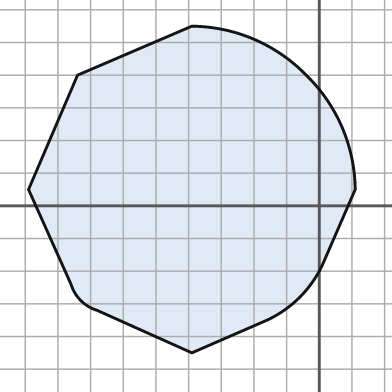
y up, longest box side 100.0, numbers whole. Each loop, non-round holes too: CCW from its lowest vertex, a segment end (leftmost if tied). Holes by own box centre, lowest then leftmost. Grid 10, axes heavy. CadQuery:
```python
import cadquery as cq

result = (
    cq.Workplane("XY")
    .moveTo(-39.0, -45.0)
    .lineTo(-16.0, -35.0)
    .threePointArc((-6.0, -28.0), (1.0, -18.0))
    .lineTo(11.0, 5.0)
    .threePointArc((7.0, 24.0), (-4.0, 40.0))
    .threePointArc((-20.0, 51.0), (-39.0, 55.0))
    .lineTo(-74.0, 40.0)
    .lineTo(-89.0, 5.0)
    .lineTo(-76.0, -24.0)
    .threePointArc((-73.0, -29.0), (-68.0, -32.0))
    .close()
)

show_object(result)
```